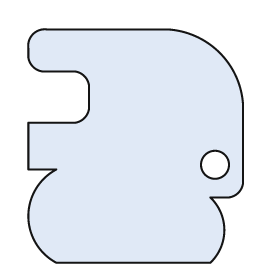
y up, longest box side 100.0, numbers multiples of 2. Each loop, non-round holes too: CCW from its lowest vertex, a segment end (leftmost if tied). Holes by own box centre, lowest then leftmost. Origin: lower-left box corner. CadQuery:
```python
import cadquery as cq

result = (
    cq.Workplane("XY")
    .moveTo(12.0, 0.0)
    .lineTo(78.0, 0.0)
    .threePointArc((84.0, 14.0), (78.0, 28.0))
    .lineTo(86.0, 28.0)
    .threePointArc((90.0, 30.0), (92.0, 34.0))
    .lineTo(92.0, 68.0)
    .threePointArc((82.0, 90.0), (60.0, 100.0))
    .lineTo(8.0, 100.0)
    .threePointArc((2.0, 98.0), (0.0, 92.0))
    .lineTo(0.0, 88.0)
    .threePointArc((2.0, 84.0), (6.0, 82.0))
    .lineTo(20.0, 82.0)
    .threePointArc((24.0, 80.0), (26.0, 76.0))
    .lineTo(26.0, 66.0)
    .threePointArc((24.0, 62.0), (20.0, 60.0))
    .lineTo(0.0, 60.0)
    .lineTo(0.0, 40.0)
    .lineTo(12.0, 40.0)
    .threePointArc((0.0, 20.0), (12.0, 0.0))
    .close()
    .moveTo(80.0, 42.0)
    .circle(6.0)
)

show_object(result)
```